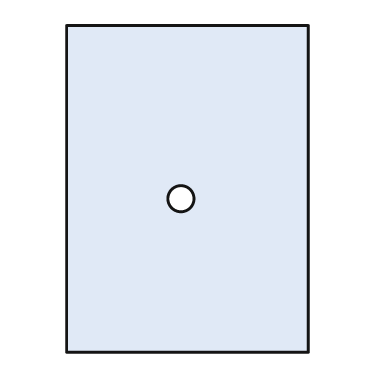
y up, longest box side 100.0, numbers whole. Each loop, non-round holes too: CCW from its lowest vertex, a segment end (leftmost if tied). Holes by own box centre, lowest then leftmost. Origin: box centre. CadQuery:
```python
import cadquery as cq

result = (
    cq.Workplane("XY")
    .moveTo(-37.0, -50.0)
    .lineTo(37.0, -50.0)
    .lineTo(37.0, 50.0)
    .lineTo(-37.0, 50.0)
    .close()
    .moveTo(-2.0, -3.0)
    .circle(4.0)
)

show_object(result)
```